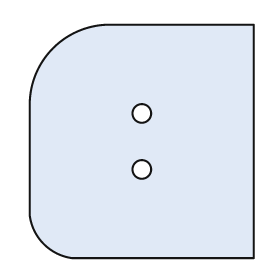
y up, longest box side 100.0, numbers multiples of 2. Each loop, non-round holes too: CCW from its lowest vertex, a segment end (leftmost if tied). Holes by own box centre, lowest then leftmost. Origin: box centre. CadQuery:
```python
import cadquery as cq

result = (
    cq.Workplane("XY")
    .moveTo(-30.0, -50.0)
    .lineTo(48.0, -50.0)
    .lineTo(48.0, 50.0)
    .lineTo(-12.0, 50.0)
    .threePointArc((-38.0, 40.0), (-48.0, 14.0))
    .lineTo(-48.0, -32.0)
    .threePointArc((-42.0, -44.0), (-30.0, -50.0))
    .close()
    .moveTo(0.0, -12.0)
    .circle(4.0)
    .moveTo(0.0, 12.0)
    .circle(4.0)
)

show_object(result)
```